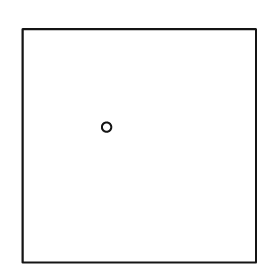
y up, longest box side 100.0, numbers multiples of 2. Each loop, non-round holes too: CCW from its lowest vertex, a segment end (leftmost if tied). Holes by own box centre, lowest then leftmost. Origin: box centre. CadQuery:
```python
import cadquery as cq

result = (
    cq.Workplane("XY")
    .moveTo(-50.0, -50.0)
    .lineTo(50.0, -50.0)
    .lineTo(50.0, 50.0)
    .lineTo(-50.0, 50.0)
    .close()
    .moveTo(-14.0, 8.0)
    .circle(2.0)
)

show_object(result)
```